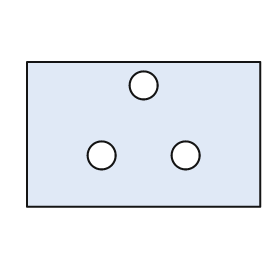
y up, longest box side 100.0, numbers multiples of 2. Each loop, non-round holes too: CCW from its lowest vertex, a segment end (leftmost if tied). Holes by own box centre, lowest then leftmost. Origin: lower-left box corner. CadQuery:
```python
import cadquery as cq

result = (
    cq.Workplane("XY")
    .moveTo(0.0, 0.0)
    .lineTo(100.0, 0.0)
    .lineTo(100.0, 62.0)
    .lineTo(0.0, 62.0)
    .close()
    .moveTo(32.0, 22.0)
    .circle(6.0)
    .moveTo(68.0, 22.0)
    .circle(6.0)
    .moveTo(50.0, 52.0)
    .circle(6.0)
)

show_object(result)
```